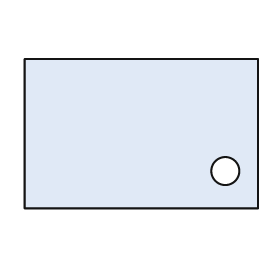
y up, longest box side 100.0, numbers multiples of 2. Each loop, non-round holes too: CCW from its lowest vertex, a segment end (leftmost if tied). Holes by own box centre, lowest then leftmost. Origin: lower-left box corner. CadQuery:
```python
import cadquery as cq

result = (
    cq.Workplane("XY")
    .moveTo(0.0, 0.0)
    .lineTo(100.0, 0.0)
    .lineTo(100.0, 64.0)
    .lineTo(0.0, 64.0)
    .close()
    .moveTo(86.0, 16.0)
    .circle(6.0)
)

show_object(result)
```